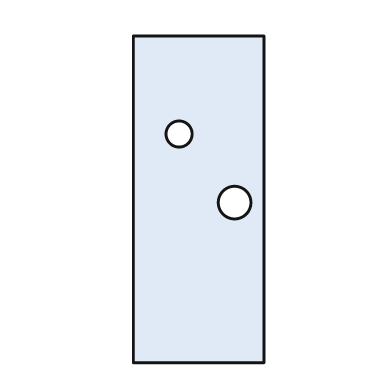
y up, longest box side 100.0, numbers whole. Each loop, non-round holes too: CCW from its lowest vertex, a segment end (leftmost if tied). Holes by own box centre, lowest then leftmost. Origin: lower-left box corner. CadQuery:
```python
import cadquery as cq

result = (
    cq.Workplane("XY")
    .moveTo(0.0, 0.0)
    .lineTo(40.0, 0.0)
    .lineTo(40.0, 100.0)
    .lineTo(0.0, 100.0)
    .close()
    .moveTo(31.0, 49.0)
    .circle(5.0)
    .moveTo(14.0, 70.0)
    .circle(4.0)
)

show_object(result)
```